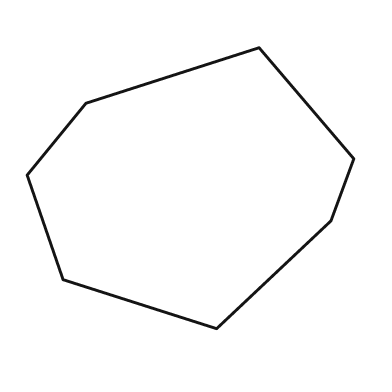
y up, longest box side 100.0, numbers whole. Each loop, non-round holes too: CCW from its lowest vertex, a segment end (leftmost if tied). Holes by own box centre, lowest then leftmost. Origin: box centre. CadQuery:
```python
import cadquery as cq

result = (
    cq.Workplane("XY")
    .moveTo(8.0, -43.0)
    .lineTo(43.0, -10.0)
    .lineTo(50.0, 9.0)
    .lineTo(21.0, 43.0)
    .lineTo(-32.0, 26.0)
    .lineTo(-50.0, 4.0)
    .lineTo(-39.0, -28.0)
    .close()
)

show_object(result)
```